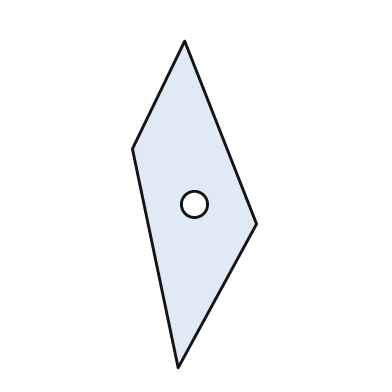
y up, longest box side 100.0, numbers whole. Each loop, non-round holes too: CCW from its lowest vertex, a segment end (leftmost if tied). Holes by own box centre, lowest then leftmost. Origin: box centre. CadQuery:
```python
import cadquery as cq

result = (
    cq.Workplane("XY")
    .moveTo(-5.0, -50.0)
    .lineTo(19.0, -6.0)
    .lineTo(-3.0, 50.0)
    .lineTo(-19.0, 17.0)
    .close()
    .moveTo(0.0, 0.0)
    .circle(4.0)
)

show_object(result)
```